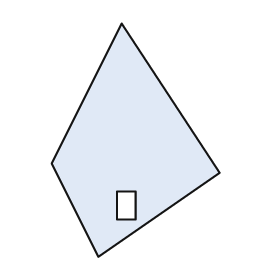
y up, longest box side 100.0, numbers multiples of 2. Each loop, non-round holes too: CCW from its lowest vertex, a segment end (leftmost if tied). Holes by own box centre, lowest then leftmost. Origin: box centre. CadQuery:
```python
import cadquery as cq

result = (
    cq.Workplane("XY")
    .moveTo(-16.0, -50.0)
    .lineTo(36.0, -14.0)
    .lineTo(-6.0, 50.0)
    .lineTo(-36.0, -10.0)
    .close()
    .moveTo(-8.0, -34.0)
    .lineTo(0.0, -34.0)
    .lineTo(0.0, -22.0)
    .lineTo(-8.0, -22.0)
    .close()
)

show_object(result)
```